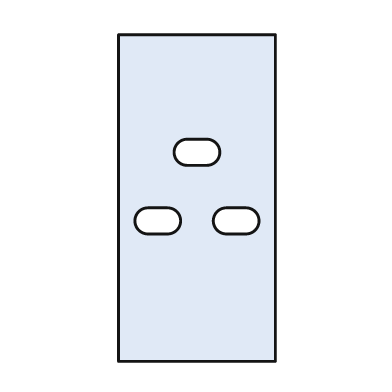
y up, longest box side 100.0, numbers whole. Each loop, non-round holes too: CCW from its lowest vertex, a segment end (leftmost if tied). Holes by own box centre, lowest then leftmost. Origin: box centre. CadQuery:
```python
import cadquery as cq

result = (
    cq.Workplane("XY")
    .moveTo(-24.0, -50.0)
    .lineTo(24.0, -50.0)
    .lineTo(24.0, 50.0)
    .lineTo(-24.0, 50.0)
    .close()
    .moveTo(-15.0, -11.0)
    .lineTo(-9.0, -11.0)
    .threePointArc((-5.0, -7.0), (-9.0, -3.0))
    .lineTo(-15.0, -3.0)
    .threePointArc((-19.0, -7.0), (-15.0, -11.0))
    .close()
    .moveTo(9.0, -11.0)
    .lineTo(15.0, -11.0)
    .threePointArc((19.0, -7.0), (15.0, -3.0))
    .lineTo(9.0, -3.0)
    .threePointArc((5.0, -7.0), (9.0, -11.0))
    .close()
    .moveTo(-3.0, 10.0)
    .lineTo(3.0, 10.0)
    .threePointArc((7.0, 14.0), (3.0, 18.0))
    .lineTo(-3.0, 18.0)
    .threePointArc((-7.0, 14.0), (-3.0, 10.0))
    .close()
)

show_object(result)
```